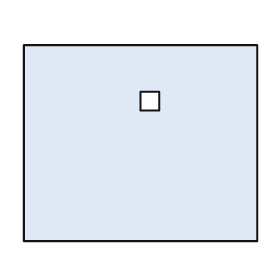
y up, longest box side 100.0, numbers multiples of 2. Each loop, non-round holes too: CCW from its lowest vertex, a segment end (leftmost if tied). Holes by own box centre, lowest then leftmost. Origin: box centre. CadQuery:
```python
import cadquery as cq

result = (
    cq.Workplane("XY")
    .moveTo(-50.0, -42.0)
    .lineTo(50.0, -42.0)
    .lineTo(50.0, 42.0)
    .lineTo(-50.0, 42.0)
    .close()
    .moveTo(0.0, 14.0)
    .lineTo(8.0, 14.0)
    .lineTo(8.0, 22.0)
    .lineTo(0.0, 22.0)
    .close()
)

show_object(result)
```